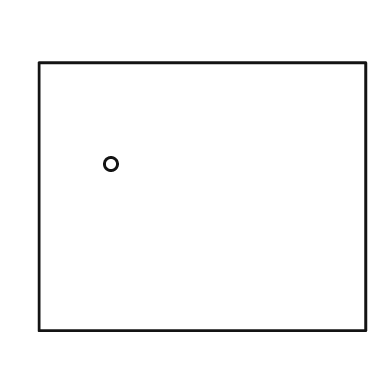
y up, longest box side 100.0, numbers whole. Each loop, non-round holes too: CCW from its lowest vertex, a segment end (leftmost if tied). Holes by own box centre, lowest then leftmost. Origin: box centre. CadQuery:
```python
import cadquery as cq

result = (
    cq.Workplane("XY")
    .moveTo(-50.0, -41.0)
    .lineTo(50.0, -41.0)
    .lineTo(50.0, 41.0)
    .lineTo(-50.0, 41.0)
    .close()
    .moveTo(-28.0, 10.0)
    .circle(2.0)
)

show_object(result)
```